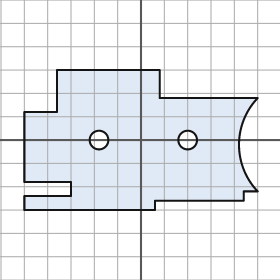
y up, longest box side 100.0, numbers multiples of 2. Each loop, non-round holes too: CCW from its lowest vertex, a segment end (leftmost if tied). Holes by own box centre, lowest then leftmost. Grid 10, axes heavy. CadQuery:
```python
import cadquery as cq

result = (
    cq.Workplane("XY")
    .moveTo(-50.0, -30.0)
    .lineTo(6.0, -30.0)
    .lineTo(6.0, -26.0)
    .lineTo(44.0, -26.0)
    .lineTo(44.0, -22.0)
    .lineTo(50.0, -22.0)
    .threePointArc((42.0, -2.0), (50.0, 18.0))
    .lineTo(8.0, 18.0)
    .lineTo(8.0, 30.0)
    .lineTo(-36.0, 30.0)
    .lineTo(-36.0, 12.0)
    .lineTo(-50.0, 12.0)
    .lineTo(-50.0, -18.0)
    .lineTo(-30.0, -18.0)
    .lineTo(-30.0, -24.0)
    .lineTo(-50.0, -24.0)
    .close()
    .moveTo(-18.0, 0.0)
    .circle(4.0)
    .moveTo(20.0, 0.0)
    .circle(4.0)
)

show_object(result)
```